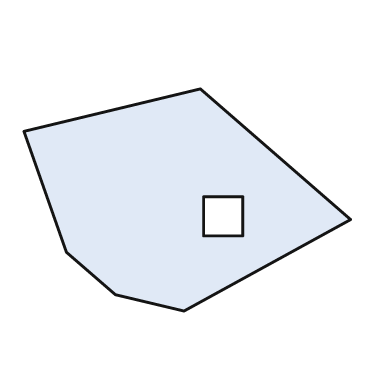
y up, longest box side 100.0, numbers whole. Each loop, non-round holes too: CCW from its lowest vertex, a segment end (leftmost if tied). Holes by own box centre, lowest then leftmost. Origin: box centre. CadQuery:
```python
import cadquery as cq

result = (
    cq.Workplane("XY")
    .moveTo(-1.0, -34.0)
    .lineTo(50.0, -6.0)
    .lineTo(4.0, 34.0)
    .lineTo(-50.0, 21.0)
    .lineTo(-37.0, -16.0)
    .lineTo(-22.0, -29.0)
    .close()
    .moveTo(5.0, -11.0)
    .lineTo(17.0, -11.0)
    .lineTo(17.0, 1.0)
    .lineTo(5.0, 1.0)
    .close()
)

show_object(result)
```